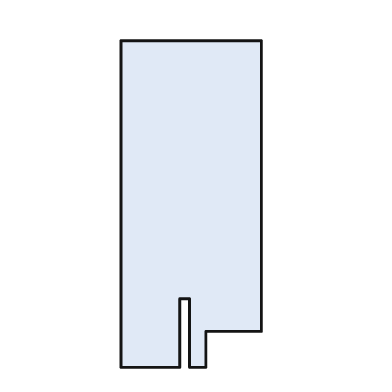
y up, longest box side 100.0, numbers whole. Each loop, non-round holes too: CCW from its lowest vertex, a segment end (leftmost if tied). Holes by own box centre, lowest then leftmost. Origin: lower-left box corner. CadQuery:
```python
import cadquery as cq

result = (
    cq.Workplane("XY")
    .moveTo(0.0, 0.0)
    .lineTo(18.0, 0.0)
    .lineTo(18.0, 21.0)
    .lineTo(21.0, 21.0)
    .lineTo(21.0, 0.0)
    .lineTo(26.0, 0.0)
    .lineTo(26.0, 11.0)
    .lineTo(43.0, 11.0)
    .lineTo(43.0, 100.0)
    .lineTo(0.0, 100.0)
    .close()
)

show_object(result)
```